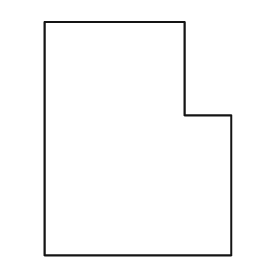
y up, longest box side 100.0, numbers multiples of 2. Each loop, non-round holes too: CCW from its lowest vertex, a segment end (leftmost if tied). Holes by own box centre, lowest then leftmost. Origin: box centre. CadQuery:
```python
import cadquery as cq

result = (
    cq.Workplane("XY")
    .moveTo(-40.0, -50.0)
    .lineTo(40.0, -50.0)
    .lineTo(40.0, 10.0)
    .lineTo(20.0, 10.0)
    .lineTo(20.0, 50.0)
    .lineTo(-40.0, 50.0)
    .close()
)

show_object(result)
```